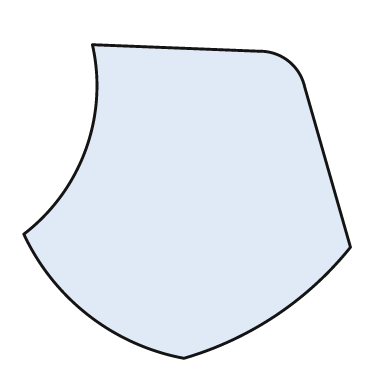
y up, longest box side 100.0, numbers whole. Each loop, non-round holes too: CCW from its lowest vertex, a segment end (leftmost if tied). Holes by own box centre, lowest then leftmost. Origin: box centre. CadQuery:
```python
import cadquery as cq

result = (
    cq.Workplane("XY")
    .moveTo(-1.0, -48.0)
    .threePointArc((27.0, -35.0), (50.0, -14.0))
    .lineTo(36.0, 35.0)
    .threePointArc((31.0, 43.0), (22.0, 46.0))
    .lineTo(-29.0, 48.0)
    .threePointArc((-31.0, 16.0), (-50.0, -10.0))
    .threePointArc((-30.0, -35.0), (-1.0, -48.0))
    .close()
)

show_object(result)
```